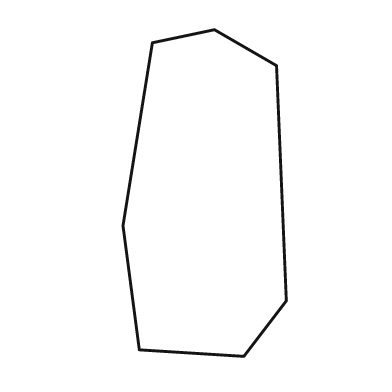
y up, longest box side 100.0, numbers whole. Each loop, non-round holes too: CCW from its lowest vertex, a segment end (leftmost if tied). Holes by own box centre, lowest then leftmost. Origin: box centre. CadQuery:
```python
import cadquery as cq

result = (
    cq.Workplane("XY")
    .moveTo(12.0, -50.0)
    .lineTo(25.0, -33.0)
    .lineTo(22.0, 39.0)
    .lineTo(3.0, 50.0)
    .lineTo(-16.0, 46.0)
    .lineTo(-25.0, -10.0)
    .lineTo(-20.0, -48.0)
    .close()
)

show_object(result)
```